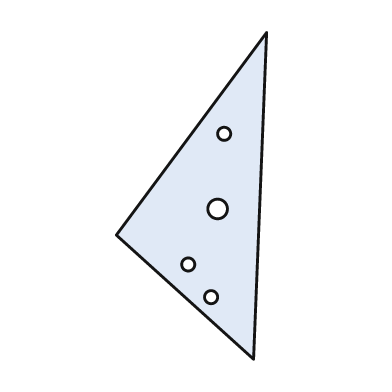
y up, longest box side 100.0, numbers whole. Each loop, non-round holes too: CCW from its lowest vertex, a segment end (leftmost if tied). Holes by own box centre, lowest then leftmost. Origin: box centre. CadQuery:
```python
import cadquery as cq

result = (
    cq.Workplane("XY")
    .moveTo(19.0, -50.0)
    .lineTo(23.0, 50.0)
    .lineTo(-23.0, -12.0)
    .close()
    .moveTo(6.0, -31.0)
    .circle(2.0)
    .moveTo(-1.0, -21.0)
    .circle(2.0)
    .moveTo(8.0, -4.0)
    .circle(3.0)
    .moveTo(10.0, 19.0)
    .circle(2.0)
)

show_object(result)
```